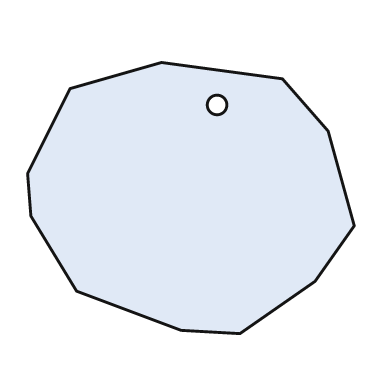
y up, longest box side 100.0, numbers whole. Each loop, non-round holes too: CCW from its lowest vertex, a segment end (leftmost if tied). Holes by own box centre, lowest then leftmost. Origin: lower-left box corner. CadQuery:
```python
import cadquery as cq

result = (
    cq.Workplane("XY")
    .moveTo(65.0, 0.0)
    .lineTo(88.0, 16.0)
    .lineTo(100.0, 33.0)
    .lineTo(92.0, 62.0)
    .lineTo(78.0, 78.0)
    .lineTo(41.0, 83.0)
    .lineTo(13.0, 75.0)
    .lineTo(0.0, 49.0)
    .lineTo(1.0, 36.0)
    .lineTo(15.0, 13.0)
    .lineTo(47.0, 1.0)
    .close()
    .moveTo(58.0, 70.0)
    .circle(3.0)
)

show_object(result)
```